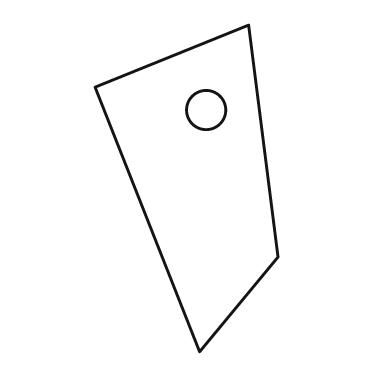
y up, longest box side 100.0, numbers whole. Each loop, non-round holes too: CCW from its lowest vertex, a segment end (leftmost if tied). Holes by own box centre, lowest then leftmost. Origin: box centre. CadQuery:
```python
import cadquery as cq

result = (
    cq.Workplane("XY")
    .moveTo(4.0, -50.0)
    .lineTo(28.0, -21.0)
    .lineTo(19.0, 50.0)
    .lineTo(-28.0, 31.0)
    .close()
    .moveTo(6.0, 24.0)
    .circle(6.0)
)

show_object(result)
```